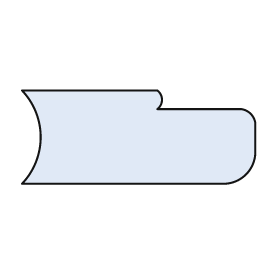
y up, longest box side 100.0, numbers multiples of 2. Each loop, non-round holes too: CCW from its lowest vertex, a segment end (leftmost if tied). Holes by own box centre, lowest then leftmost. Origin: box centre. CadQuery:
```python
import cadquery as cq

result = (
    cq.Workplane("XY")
    .moveTo(-50.0, -20.0)
    .lineTo(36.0, -20.0)
    .threePointArc((46.0, -16.0), (50.0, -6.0))
    .lineTo(50.0, 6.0)
    .threePointArc((48.0, 10.0), (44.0, 12.0))
    .lineTo(8.0, 12.0)
    .threePointArc((10.0, 16.0), (8.0, 20.0))
    .lineTo(-50.0, 20.0)
    .threePointArc((-42.0, 0.0), (-50.0, -20.0))
    .close()
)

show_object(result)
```